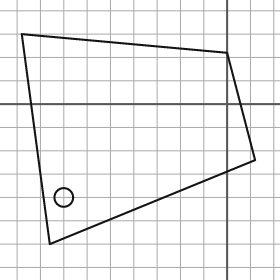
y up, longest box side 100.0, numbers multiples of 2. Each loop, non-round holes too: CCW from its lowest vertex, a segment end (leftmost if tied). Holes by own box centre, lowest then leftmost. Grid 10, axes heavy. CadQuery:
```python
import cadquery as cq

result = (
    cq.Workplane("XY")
    .moveTo(-76.0, -60.0)
    .lineTo(12.0, -24.0)
    .lineTo(0.0, 22.0)
    .lineTo(-88.0, 30.0)
    .close()
    .moveTo(-70.0, -40.0)
    .circle(4.0)
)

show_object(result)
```